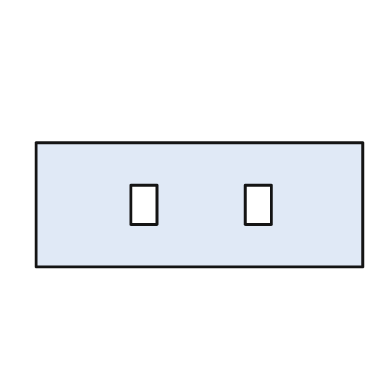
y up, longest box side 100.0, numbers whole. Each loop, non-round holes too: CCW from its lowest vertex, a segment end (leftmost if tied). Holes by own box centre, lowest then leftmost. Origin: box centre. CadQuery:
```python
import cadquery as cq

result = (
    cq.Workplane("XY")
    .moveTo(-50.0, -19.0)
    .lineTo(50.0, -19.0)
    .lineTo(50.0, 19.0)
    .lineTo(-50.0, 19.0)
    .close()
    .moveTo(-21.0, -6.0)
    .lineTo(-13.0, -6.0)
    .lineTo(-13.0, 6.0)
    .lineTo(-21.0, 6.0)
    .close()
    .moveTo(14.0, -6.0)
    .lineTo(22.0, -6.0)
    .lineTo(22.0, 6.0)
    .lineTo(14.0, 6.0)
    .close()
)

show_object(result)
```